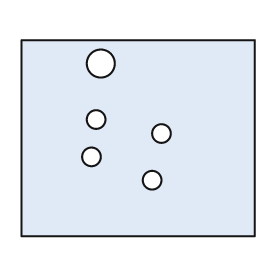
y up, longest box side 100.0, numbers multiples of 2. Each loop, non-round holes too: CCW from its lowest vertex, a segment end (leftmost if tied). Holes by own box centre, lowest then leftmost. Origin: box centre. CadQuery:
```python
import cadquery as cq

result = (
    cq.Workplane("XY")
    .moveTo(-50.0, -42.0)
    .lineTo(50.0, -42.0)
    .lineTo(50.0, 42.0)
    .lineTo(-50.0, 42.0)
    .close()
    .moveTo(6.0, -18.0)
    .circle(4.0)
    .moveTo(-20.0, -8.0)
    .circle(4.0)
    .moveTo(10.0, 2.0)
    .circle(4.0)
    .moveTo(-18.0, 8.0)
    .circle(4.0)
    .moveTo(-16.0, 32.0)
    .circle(6.0)
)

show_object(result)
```